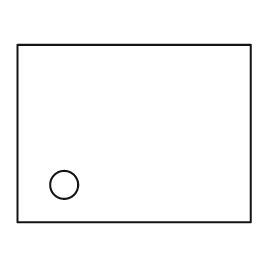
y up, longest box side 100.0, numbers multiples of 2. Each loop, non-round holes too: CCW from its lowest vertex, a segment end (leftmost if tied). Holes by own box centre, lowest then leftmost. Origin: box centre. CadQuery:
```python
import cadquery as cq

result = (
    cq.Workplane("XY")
    .moveTo(-50.0, -38.0)
    .lineTo(50.0, -38.0)
    .lineTo(50.0, 38.0)
    .lineTo(-50.0, 38.0)
    .close()
    .moveTo(-30.0, -22.0)
    .circle(6.0)
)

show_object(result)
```